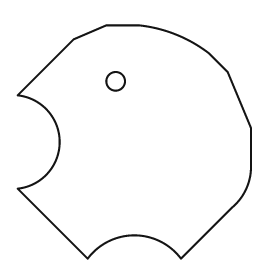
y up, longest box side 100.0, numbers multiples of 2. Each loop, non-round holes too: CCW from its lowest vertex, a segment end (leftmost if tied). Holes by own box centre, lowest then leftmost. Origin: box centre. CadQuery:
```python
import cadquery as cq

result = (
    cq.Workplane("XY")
    .moveTo(-20.0, -50.0)
    .threePointArc((0.0, -40.0), (20.0, -50.0))
    .lineTo(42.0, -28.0)
    .threePointArc((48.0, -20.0), (50.0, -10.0))
    .lineTo(50.0, 6.0)
    .lineTo(40.0, 30.0)
    .lineTo(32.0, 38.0)
    .threePointArc((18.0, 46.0), (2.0, 50.0))
    .lineTo(-12.0, 50.0)
    .lineTo(-26.0, 44.0)
    .lineTo(-50.0, 20.0)
    .threePointArc((-32.0, 0.0), (-50.0, -20.0))
    .close()
    .moveTo(-8.0, 26.0)
    .circle(4.0)
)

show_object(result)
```